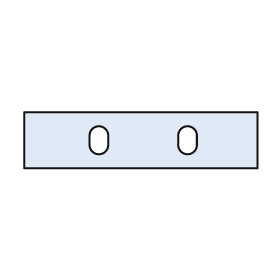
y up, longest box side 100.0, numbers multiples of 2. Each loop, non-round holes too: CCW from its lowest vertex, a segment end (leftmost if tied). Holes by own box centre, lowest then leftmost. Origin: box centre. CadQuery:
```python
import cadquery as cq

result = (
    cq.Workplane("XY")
    .moveTo(-50.0, -12.0)
    .lineTo(50.0, -12.0)
    .lineTo(50.0, 12.0)
    .lineTo(-50.0, 12.0)
    .close()
    .moveTo(-22.0, -2.0)
    .threePointArc((-18.0, -6.0), (-14.0, -2.0))
    .lineTo(-14.0, 2.0)
    .threePointArc((-18.0, 6.0), (-22.0, 2.0))
    .close()
    .moveTo(16.0, -2.0)
    .threePointArc((20.0, -6.0), (24.0, -2.0))
    .lineTo(24.0, 2.0)
    .threePointArc((20.0, 6.0), (16.0, 2.0))
    .close()
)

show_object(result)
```